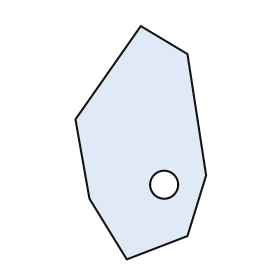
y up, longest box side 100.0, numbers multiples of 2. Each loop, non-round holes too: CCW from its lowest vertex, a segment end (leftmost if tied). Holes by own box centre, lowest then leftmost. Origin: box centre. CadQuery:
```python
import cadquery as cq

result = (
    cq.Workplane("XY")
    .moveTo(-6.0, -50.0)
    .lineTo(20.0, -40.0)
    .lineTo(28.0, -14.0)
    .lineTo(20.0, 38.0)
    .lineTo(0.0, 50.0)
    .lineTo(-28.0, 10.0)
    .lineTo(-22.0, -24.0)
    .close()
    .moveTo(10.0, -18.0)
    .circle(6.0)
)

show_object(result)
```